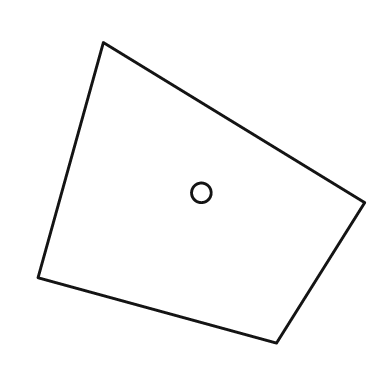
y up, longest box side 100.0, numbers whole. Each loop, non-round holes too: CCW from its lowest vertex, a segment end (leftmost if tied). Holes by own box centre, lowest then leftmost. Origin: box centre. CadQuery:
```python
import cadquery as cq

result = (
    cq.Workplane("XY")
    .moveTo(23.0, -46.0)
    .lineTo(50.0, -3.0)
    .lineTo(-30.0, 46.0)
    .lineTo(-50.0, -26.0)
    .close()
    .moveTo(0.0, 0.0)
    .circle(3.0)
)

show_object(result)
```